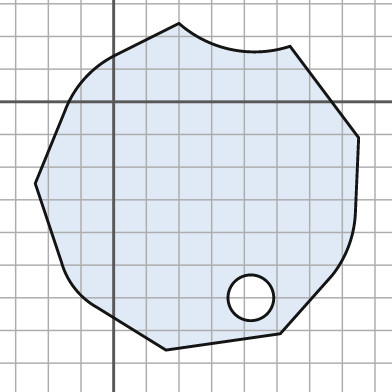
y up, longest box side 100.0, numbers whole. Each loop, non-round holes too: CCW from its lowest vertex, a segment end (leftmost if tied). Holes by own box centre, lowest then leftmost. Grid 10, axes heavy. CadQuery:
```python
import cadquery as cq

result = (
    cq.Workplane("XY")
    .moveTo(16.0, -76.0)
    .lineTo(51.0, -71.0)
    .lineTo(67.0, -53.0)
    .threePointArc((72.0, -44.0), (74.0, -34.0))
    .lineTo(75.0, -11.0)
    .lineTo(54.0, 17.0)
    .threePointArc((36.0, 16.0), (20.0, 24.0))
    .lineTo(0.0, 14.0)
    .threePointArc((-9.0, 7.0), (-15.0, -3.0))
    .lineTo(-24.0, -25.0)
    .lineTo(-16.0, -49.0)
    .threePointArc((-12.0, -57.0), (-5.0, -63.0))
    .close()
    .moveTo(42.0, -60.0)
    .circle(7.0)
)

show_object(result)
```